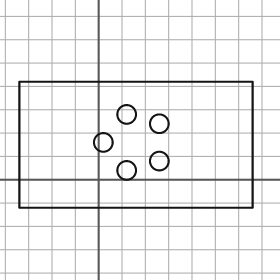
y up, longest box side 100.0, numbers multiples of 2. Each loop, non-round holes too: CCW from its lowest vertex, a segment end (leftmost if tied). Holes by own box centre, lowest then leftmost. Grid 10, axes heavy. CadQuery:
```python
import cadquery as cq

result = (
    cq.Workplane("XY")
    .moveTo(-34.0, -12.0)
    .lineTo(66.0, -12.0)
    .lineTo(66.0, 42.0)
    .lineTo(-34.0, 42.0)
    .close()
    .moveTo(12.0, 4.0)
    .circle(4.0)
    .moveTo(26.0, 8.0)
    .circle(4.0)
    .moveTo(2.0, 16.0)
    .circle(4.0)
    .moveTo(26.0, 24.0)
    .circle(4.0)
    .moveTo(12.0, 28.0)
    .circle(4.0)
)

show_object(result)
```